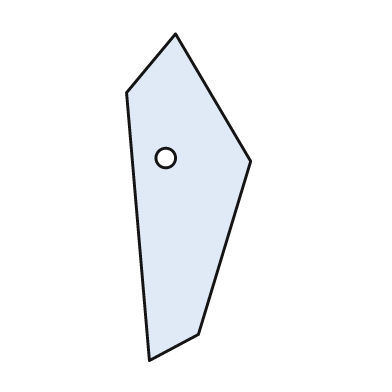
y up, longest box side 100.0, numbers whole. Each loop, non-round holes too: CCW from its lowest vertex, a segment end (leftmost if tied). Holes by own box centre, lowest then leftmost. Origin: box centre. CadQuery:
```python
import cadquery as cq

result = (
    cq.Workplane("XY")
    .moveTo(-12.0, -50.0)
    .lineTo(3.0, -42.0)
    .lineTo(19.0, 11.0)
    .lineTo(-4.0, 50.0)
    .lineTo(-19.0, 32.0)
    .close()
    .moveTo(-7.0, 12.0)
    .circle(3.0)
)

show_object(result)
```